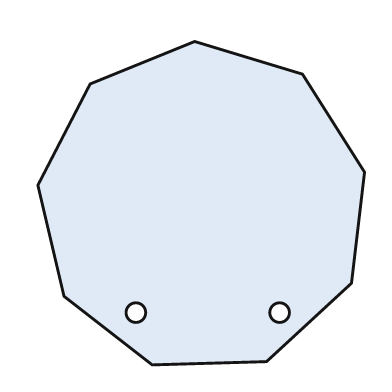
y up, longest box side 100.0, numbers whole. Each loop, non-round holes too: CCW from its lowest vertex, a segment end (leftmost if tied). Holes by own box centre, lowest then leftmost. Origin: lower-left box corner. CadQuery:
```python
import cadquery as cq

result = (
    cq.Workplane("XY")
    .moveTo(35.0, 0.0)
    .lineTo(70.0, 1.0)
    .lineTo(96.0, 25.0)
    .lineTo(100.0, 59.0)
    .lineTo(81.0, 89.0)
    .lineTo(48.0, 99.0)
    .lineTo(16.0, 86.0)
    .lineTo(0.0, 55.0)
    .lineTo(8.0, 21.0)
    .close()
    .moveTo(30.0, 16.0)
    .circle(3.0)
    .moveTo(74.0, 16.0)
    .circle(3.0)
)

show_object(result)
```